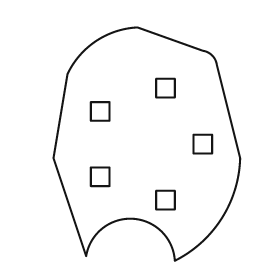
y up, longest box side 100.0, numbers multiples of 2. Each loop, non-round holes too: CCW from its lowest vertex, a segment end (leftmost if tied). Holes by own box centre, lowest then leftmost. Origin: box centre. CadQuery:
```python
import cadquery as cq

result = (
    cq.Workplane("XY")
    .moveTo(12.0, -50.0)
    .threePointArc((32.0, -32.0), (40.0, -6.0))
    .lineTo(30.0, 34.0)
    .threePointArc((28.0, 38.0), (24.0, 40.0))
    .lineTo(-4.0, 50.0)
    .threePointArc((-22.0, 44.0), (-34.0, 30.0))
    .lineTo(-40.0, -6.0)
    .lineTo(-26.0, -48.0)
    .threePointArc((-6.0, -32.0), (12.0, -50.0))
    .close()
    .moveTo(4.0, -28.0)
    .lineTo(12.0, -28.0)
    .lineTo(12.0, -20.0)
    .lineTo(4.0, -20.0)
    .close()
    .moveTo(-24.0, -18.0)
    .lineTo(-16.0, -18.0)
    .lineTo(-16.0, -10.0)
    .lineTo(-24.0, -10.0)
    .close()
    .moveTo(20.0, -4.0)
    .lineTo(28.0, -4.0)
    .lineTo(28.0, 4.0)
    .lineTo(20.0, 4.0)
    .close()
    .moveTo(-24.0, 10.0)
    .lineTo(-16.0, 10.0)
    .lineTo(-16.0, 18.0)
    .lineTo(-24.0, 18.0)
    .close()
    .moveTo(4.0, 20.0)
    .lineTo(12.0, 20.0)
    .lineTo(12.0, 28.0)
    .lineTo(4.0, 28.0)
    .close()
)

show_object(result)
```